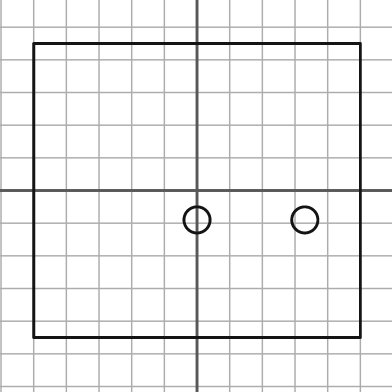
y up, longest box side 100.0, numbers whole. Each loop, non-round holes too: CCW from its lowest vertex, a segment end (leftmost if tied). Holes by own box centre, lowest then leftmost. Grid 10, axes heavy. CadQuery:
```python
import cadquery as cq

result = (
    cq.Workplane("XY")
    .moveTo(-50.0, -45.0)
    .lineTo(50.0, -45.0)
    .lineTo(50.0, 45.0)
    .lineTo(-50.0, 45.0)
    .close()
    .moveTo(0.0, -9.0)
    .circle(4.0)
    .moveTo(33.0, -9.0)
    .circle(4.0)
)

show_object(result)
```